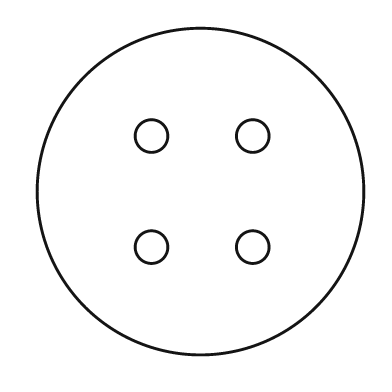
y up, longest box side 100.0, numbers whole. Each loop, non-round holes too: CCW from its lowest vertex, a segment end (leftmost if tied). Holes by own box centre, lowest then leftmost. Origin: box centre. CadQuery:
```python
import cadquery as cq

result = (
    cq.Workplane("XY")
    .moveTo(0.0, 0.0)
    .circle(50.0)
    .moveTo(-15.0, -17.0)
    .circle(5.0)
    .moveTo(16.0, -17.0)
    .circle(5.0)
    .moveTo(-15.0, 17.0)
    .circle(5.0)
    .moveTo(16.0, 17.0)
    .circle(5.0)
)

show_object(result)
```